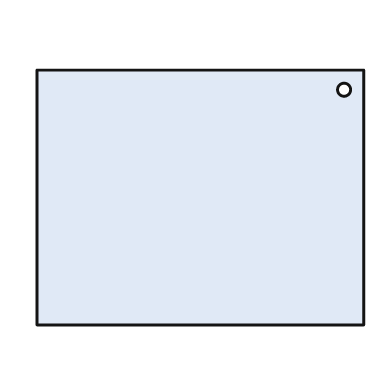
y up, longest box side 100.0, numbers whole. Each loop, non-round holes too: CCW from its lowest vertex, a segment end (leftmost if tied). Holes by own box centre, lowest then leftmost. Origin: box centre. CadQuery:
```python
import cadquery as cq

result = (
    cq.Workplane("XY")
    .moveTo(-50.0, -39.0)
    .lineTo(50.0, -39.0)
    .lineTo(50.0, 39.0)
    .lineTo(-50.0, 39.0)
    .close()
    .moveTo(44.0, 33.0)
    .circle(2.0)
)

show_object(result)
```